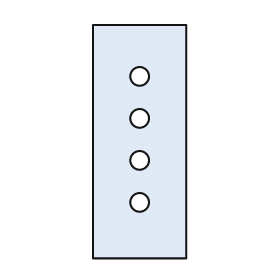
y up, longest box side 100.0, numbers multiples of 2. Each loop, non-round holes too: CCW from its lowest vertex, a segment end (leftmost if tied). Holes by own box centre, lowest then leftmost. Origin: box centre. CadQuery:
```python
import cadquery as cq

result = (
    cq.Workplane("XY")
    .moveTo(-20.0, -50.0)
    .lineTo(20.0, -50.0)
    .lineTo(20.0, 50.0)
    .lineTo(-20.0, 50.0)
    .close()
    .moveTo(0.0, -26.0)
    .circle(4.0)
    .moveTo(0.0, -8.0)
    .circle(4.0)
    .moveTo(0.0, 10.0)
    .circle(4.0)
    .moveTo(0.0, 28.0)
    .circle(4.0)
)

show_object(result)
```